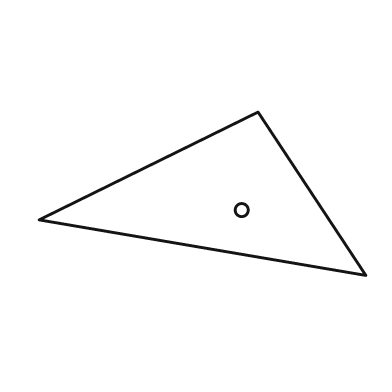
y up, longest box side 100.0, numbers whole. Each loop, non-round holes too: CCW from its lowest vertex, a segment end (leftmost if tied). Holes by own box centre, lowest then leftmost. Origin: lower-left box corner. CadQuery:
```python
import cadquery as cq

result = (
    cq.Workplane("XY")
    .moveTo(100.0, 0.0)
    .lineTo(67.0, 50.0)
    .lineTo(0.0, 17.0)
    .close()
    .moveTo(62.0, 20.0)
    .circle(2.0)
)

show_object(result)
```